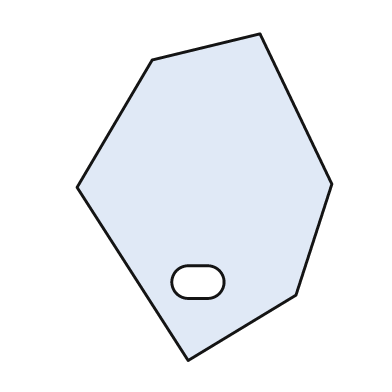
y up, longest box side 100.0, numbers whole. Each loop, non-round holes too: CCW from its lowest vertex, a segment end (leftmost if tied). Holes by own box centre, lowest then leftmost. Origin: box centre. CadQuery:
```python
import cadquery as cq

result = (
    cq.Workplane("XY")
    .moveTo(-5.0, -50.0)
    .lineTo(28.0, -30.0)
    .lineTo(39.0, 4.0)
    .lineTo(17.0, 50.0)
    .lineTo(-16.0, 42.0)
    .lineTo(-39.0, 3.0)
    .close()
    .moveTo(-5.0, -31.0)
    .lineTo(1.0, -31.0)
    .threePointArc((6.0, -26.0), (1.0, -21.0))
    .lineTo(-5.0, -21.0)
    .threePointArc((-10.0, -26.0), (-5.0, -31.0))
    .close()
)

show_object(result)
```